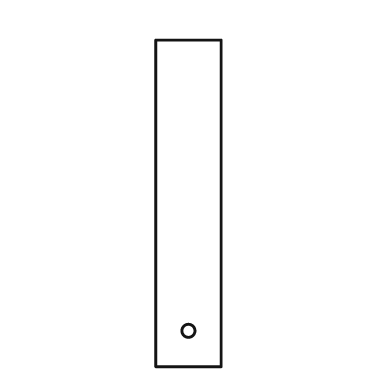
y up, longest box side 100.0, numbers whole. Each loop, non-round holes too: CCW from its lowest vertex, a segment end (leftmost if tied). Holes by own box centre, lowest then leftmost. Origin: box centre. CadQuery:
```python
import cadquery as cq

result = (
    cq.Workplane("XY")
    .moveTo(-10.0, -50.0)
    .lineTo(10.0, -50.0)
    .lineTo(10.0, 50.0)
    .lineTo(-10.0, 50.0)
    .close()
    .moveTo(0.0, -39.0)
    .circle(2.0)
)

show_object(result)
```